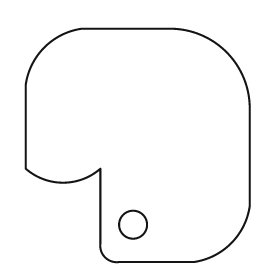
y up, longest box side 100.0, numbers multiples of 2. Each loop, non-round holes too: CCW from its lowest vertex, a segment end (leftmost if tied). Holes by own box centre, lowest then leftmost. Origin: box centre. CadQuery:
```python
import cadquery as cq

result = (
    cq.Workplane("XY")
    .moveTo(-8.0, -50.0)
    .lineTo(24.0, -50.0)
    .threePointArc((40.0, -42.0), (48.0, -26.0))
    .lineTo(48.0, 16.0)
    .threePointArc((38.0, 40.0), (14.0, 50.0))
    .lineTo(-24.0, 50.0)
    .threePointArc((-40.0, 42.0), (-48.0, 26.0))
    .lineTo(-48.0, -10.0)
    .threePointArc((-32.0, -16.0), (-16.0, -10.0))
    .lineTo(-16.0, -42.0)
    .threePointArc((-14.0, -48.0), (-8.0, -50.0))
    .close()
    .moveTo(-2.0, -34.0)
    .circle(6.0)
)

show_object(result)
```